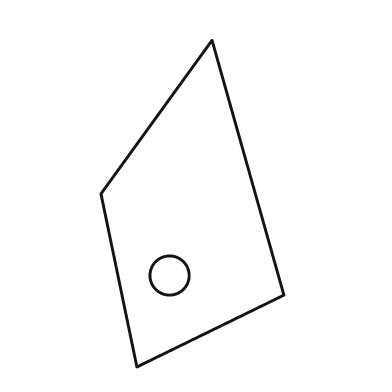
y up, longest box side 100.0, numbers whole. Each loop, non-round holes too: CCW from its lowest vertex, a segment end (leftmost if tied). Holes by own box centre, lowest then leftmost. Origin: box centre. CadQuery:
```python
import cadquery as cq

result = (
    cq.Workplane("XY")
    .moveTo(-17.0, -50.0)
    .lineTo(28.0, -28.0)
    .lineTo(6.0, 50.0)
    .lineTo(-28.0, 3.0)
    .close()
    .moveTo(-7.0, -22.0)
    .circle(6.0)
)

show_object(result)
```